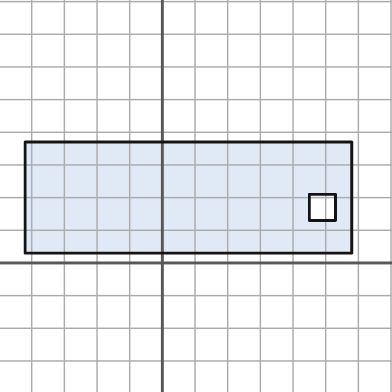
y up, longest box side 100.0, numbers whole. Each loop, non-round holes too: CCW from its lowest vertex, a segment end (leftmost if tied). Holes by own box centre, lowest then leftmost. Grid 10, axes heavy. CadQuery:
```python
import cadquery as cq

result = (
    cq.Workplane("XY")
    .moveTo(-42.0, 3.0)
    .lineTo(58.0, 3.0)
    .lineTo(58.0, 37.0)
    .lineTo(-42.0, 37.0)
    .close()
    .moveTo(45.0, 13.0)
    .lineTo(53.0, 13.0)
    .lineTo(53.0, 21.0)
    .lineTo(45.0, 21.0)
    .close()
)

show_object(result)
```